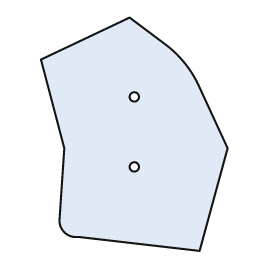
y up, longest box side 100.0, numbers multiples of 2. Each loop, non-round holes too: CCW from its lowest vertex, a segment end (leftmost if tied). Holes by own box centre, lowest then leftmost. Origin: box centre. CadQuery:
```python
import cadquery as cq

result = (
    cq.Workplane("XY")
    .moveTo(28.0, -50.0)
    .lineTo(40.0, -6.0)
    .lineTo(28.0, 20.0)
    .threePointArc((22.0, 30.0), (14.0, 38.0))
    .lineTo(-2.0, 50.0)
    .lineTo(-40.0, 32.0)
    .lineTo(-30.0, -6.0)
    .lineTo(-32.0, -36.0)
    .threePointArc((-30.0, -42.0), (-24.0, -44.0))
    .close()
    .moveTo(0.0, -14.0)
    .circle(2.0)
    .moveTo(0.0, 16.0)
    .circle(2.0)
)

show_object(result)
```